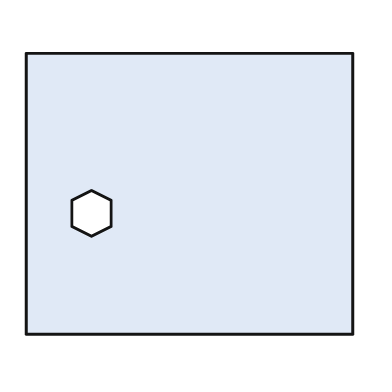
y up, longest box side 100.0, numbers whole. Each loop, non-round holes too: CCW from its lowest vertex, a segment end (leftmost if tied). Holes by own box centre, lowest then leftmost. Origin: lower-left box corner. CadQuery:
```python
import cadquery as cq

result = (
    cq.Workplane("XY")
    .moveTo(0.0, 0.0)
    .lineTo(100.0, 0.0)
    .lineTo(100.0, 86.0)
    .lineTo(0.0, 86.0)
    .close()
    .moveTo(20.0, 30.0)
    .lineTo(26.0, 33.0)
    .lineTo(26.0, 41.0)
    .lineTo(20.0, 44.0)
    .lineTo(14.0, 41.0)
    .lineTo(14.0, 33.0)
    .close()
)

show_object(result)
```